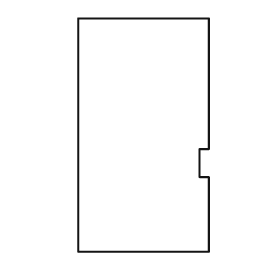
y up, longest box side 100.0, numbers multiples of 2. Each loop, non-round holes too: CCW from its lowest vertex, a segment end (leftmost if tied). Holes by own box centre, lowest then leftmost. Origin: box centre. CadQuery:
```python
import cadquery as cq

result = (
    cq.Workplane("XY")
    .moveTo(-28.0, -50.0)
    .lineTo(28.0, -50.0)
    .lineTo(28.0, -18.0)
    .lineTo(24.0, -18.0)
    .lineTo(24.0, -6.0)
    .lineTo(28.0, -6.0)
    .lineTo(28.0, 50.0)
    .lineTo(-28.0, 50.0)
    .close()
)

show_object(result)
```